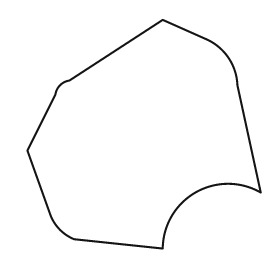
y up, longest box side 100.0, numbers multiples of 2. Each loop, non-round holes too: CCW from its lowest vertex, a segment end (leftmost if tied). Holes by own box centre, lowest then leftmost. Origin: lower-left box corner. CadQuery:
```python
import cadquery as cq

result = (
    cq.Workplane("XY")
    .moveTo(58.0, 0.0)
    .threePointArc((72.0, 24.0), (100.0, 24.0))
    .lineTo(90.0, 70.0)
    .threePointArc((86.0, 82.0), (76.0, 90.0))
    .lineTo(58.0, 98.0)
    .lineTo(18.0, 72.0)
    .threePointArc((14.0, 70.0), (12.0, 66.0))
    .lineTo(0.0, 42.0)
    .lineTo(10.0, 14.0)
    .threePointArc((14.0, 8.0), (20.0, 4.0))
    .close()
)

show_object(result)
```